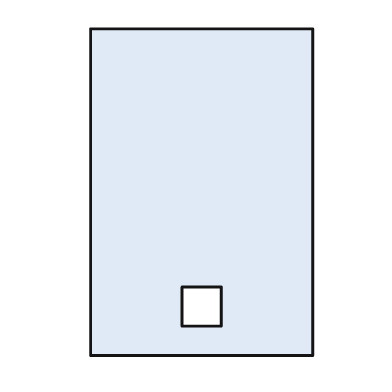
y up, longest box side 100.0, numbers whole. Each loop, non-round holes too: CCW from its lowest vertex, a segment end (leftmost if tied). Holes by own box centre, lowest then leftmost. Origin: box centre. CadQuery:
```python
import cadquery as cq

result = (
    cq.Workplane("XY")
    .moveTo(-34.0, -50.0)
    .lineTo(34.0, -50.0)
    .lineTo(34.0, 50.0)
    .lineTo(-34.0, 50.0)
    .close()
    .moveTo(-6.0, -41.0)
    .lineTo(6.0, -41.0)
    .lineTo(6.0, -29.0)
    .lineTo(-6.0, -29.0)
    .close()
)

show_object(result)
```